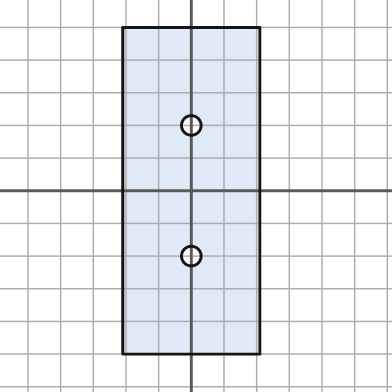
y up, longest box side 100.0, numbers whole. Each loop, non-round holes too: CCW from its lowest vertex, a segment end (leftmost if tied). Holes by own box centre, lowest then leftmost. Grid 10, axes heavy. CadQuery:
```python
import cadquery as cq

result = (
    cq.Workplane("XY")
    .moveTo(-21.0, -50.0)
    .lineTo(21.0, -50.0)
    .lineTo(21.0, 50.0)
    .lineTo(-21.0, 50.0)
    .close()
    .moveTo(0.0, -20.0)
    .circle(3.0)
    .moveTo(0.0, 20.0)
    .circle(3.0)
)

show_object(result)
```